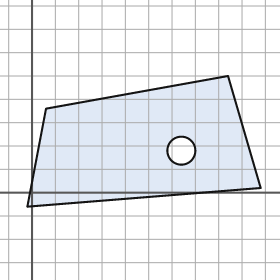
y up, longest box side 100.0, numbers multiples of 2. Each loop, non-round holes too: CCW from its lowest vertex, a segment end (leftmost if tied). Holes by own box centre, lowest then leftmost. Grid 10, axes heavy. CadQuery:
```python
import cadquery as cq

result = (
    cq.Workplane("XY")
    .moveTo(-2.0, -6.0)
    .lineTo(98.0, 2.0)
    .lineTo(84.0, 50.0)
    .lineTo(6.0, 36.0)
    .close()
    .moveTo(64.0, 18.0)
    .circle(6.0)
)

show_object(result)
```